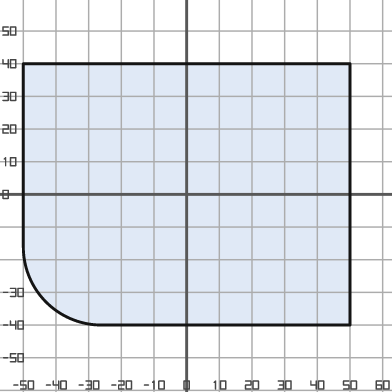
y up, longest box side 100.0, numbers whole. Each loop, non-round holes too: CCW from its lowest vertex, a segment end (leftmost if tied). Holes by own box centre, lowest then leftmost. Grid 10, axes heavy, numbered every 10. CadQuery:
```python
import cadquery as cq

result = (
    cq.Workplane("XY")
    .moveTo(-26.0, -40.0)
    .lineTo(50.0, -40.0)
    .lineTo(50.0, 40.0)
    .lineTo(-50.0, 40.0)
    .lineTo(-50.0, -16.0)
    .threePointArc((-43.0, -33.0), (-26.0, -40.0))
    .close()
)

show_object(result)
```